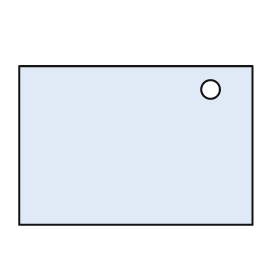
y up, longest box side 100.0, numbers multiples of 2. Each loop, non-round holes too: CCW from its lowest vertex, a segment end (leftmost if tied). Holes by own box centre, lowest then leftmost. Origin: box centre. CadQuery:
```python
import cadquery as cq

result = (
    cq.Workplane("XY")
    .moveTo(-50.0, -34.0)
    .lineTo(50.0, -34.0)
    .lineTo(50.0, 34.0)
    .lineTo(-50.0, 34.0)
    .close()
    .moveTo(32.0, 24.0)
    .circle(4.0)
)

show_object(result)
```